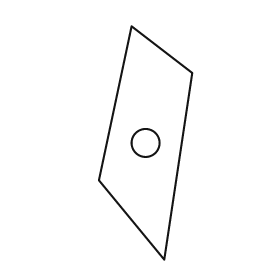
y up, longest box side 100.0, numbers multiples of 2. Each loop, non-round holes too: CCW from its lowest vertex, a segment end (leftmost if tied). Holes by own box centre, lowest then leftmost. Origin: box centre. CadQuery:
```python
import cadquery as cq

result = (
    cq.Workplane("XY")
    .moveTo(8.0, -50.0)
    .lineTo(20.0, 30.0)
    .lineTo(-6.0, 50.0)
    .lineTo(-20.0, -16.0)
    .close()
    .moveTo(0.0, 0.0)
    .circle(6.0)
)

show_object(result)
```